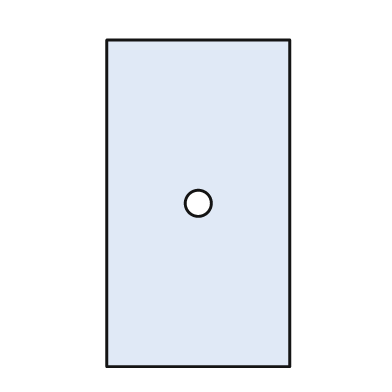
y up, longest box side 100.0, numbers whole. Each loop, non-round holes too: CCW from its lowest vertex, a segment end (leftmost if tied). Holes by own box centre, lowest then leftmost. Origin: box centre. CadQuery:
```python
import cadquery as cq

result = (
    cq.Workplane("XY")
    .moveTo(-28.0, -50.0)
    .lineTo(28.0, -50.0)
    .lineTo(28.0, 50.0)
    .lineTo(-28.0, 50.0)
    .close()
    .moveTo(0.0, 0.0)
    .circle(4.0)
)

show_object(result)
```